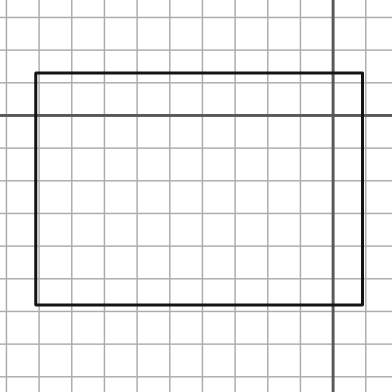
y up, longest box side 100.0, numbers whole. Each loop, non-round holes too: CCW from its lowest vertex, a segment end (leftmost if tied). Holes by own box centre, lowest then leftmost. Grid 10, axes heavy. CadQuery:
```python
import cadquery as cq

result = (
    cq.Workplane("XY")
    .moveTo(-91.0, -58.0)
    .lineTo(9.0, -58.0)
    .lineTo(9.0, 13.0)
    .lineTo(-91.0, 13.0)
    .close()
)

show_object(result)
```